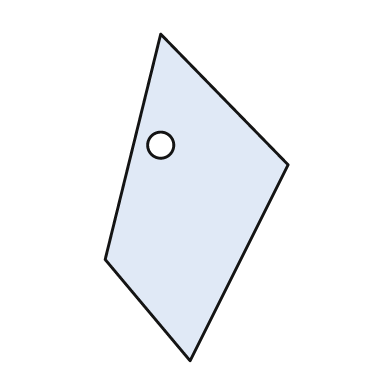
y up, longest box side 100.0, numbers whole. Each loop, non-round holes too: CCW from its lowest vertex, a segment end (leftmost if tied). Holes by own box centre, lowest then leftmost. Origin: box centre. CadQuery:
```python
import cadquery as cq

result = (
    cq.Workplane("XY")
    .moveTo(-2.0, -50.0)
    .lineTo(28.0, 10.0)
    .lineTo(-11.0, 50.0)
    .lineTo(-28.0, -19.0)
    .close()
    .moveTo(-11.0, 16.0)
    .circle(4.0)
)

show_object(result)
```